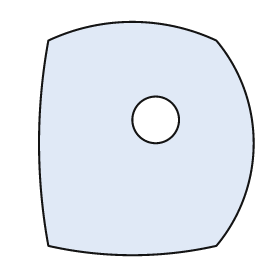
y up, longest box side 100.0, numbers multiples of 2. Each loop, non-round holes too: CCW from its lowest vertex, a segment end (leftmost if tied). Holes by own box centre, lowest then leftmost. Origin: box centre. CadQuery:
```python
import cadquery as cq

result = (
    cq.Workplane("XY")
    .moveTo(-42.0, -46.0)
    .threePointArc((-6.0, -50.0), (30.0, -46.0))
    .threePointArc((46.0, -2.0), (30.0, 42.0))
    .threePointArc((-6.0, 50.0), (-42.0, 42.0))
    .threePointArc((-46.0, -2.0), (-42.0, -46.0))
    .close()
    .moveTo(4.0, 8.0)
    .circle(10.0)
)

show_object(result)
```